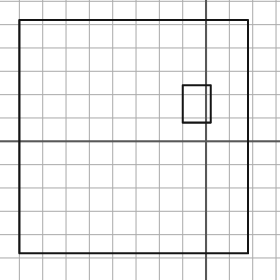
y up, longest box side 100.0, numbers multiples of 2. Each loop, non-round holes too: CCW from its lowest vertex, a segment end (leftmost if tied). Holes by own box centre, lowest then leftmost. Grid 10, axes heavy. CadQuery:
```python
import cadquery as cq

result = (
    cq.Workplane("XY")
    .moveTo(-80.0, -48.0)
    .lineTo(18.0, -48.0)
    .lineTo(18.0, 52.0)
    .lineTo(-80.0, 52.0)
    .close()
    .moveTo(-10.0, 8.0)
    .lineTo(2.0, 8.0)
    .lineTo(2.0, 24.0)
    .lineTo(-10.0, 24.0)
    .close()
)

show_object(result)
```